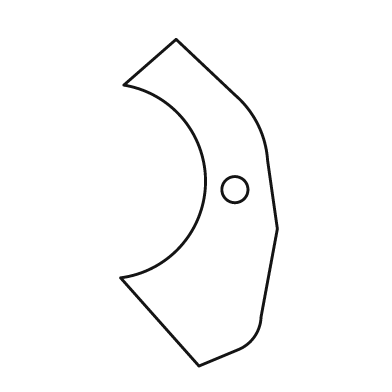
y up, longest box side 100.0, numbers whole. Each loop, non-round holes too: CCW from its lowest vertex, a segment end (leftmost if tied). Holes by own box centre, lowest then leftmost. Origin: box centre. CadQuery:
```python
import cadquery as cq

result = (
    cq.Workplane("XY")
    .moveTo(0.0, -50.0)
    .lineTo(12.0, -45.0)
    .threePointArc((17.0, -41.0), (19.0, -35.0))
    .lineTo(24.0, -8.0)
    .lineTo(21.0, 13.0)
    .threePointArc((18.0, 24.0), (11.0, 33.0))
    .lineTo(-7.0, 50.0)
    .lineTo(-23.0, 36.0)
    .threePointArc((2.0, 6.0), (-24.0, -23.0))
    .close()
    .moveTo(11.0, 4.0)
    .circle(4.0)
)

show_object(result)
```